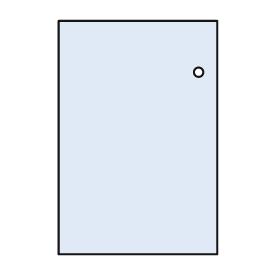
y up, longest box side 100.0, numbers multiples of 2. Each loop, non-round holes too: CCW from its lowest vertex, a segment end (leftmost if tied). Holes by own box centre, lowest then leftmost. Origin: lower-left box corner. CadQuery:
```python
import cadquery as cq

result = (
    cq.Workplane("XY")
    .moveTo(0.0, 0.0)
    .lineTo(68.0, 0.0)
    .lineTo(68.0, 100.0)
    .lineTo(0.0, 100.0)
    .close()
    .moveTo(60.0, 78.0)
    .circle(2.0)
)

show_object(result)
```